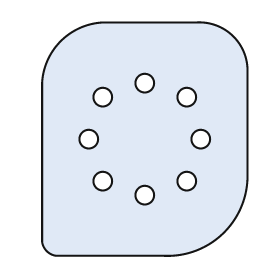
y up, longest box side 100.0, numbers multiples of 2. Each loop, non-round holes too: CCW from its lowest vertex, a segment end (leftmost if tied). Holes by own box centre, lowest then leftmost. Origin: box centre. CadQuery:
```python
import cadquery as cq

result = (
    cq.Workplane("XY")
    .moveTo(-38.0, -50.0)
    .lineTo(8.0, -50.0)
    .threePointArc((34.0, -40.0), (44.0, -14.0))
    .lineTo(44.0, 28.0)
    .threePointArc((38.0, 44.0), (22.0, 50.0))
    .lineTo(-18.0, 50.0)
    .threePointArc((-36.0, 42.0), (-44.0, 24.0))
    .lineTo(-44.0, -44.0)
    .threePointArc((-42.0, -48.0), (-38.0, -50.0))
    .close()
    .moveTo(0.0, -24.0)
    .circle(4.0)
    .moveTo(-18.0, -18.0)
    .circle(4.0)
    .moveTo(18.0, -18.0)
    .circle(4.0)
    .moveTo(-24.0, 0.0)
    .circle(4.0)
    .moveTo(24.0, 0.0)
    .circle(4.0)
    .moveTo(-18.0, 18.0)
    .circle(4.0)
    .moveTo(18.0, 18.0)
    .circle(4.0)
    .moveTo(0.0, 24.0)
    .circle(4.0)
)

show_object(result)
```